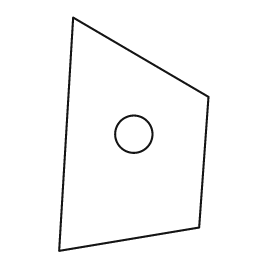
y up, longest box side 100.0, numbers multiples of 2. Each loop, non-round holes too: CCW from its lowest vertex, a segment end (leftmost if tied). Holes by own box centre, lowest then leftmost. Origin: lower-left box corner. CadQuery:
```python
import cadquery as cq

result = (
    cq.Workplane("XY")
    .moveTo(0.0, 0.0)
    .lineTo(60.0, 10.0)
    .lineTo(64.0, 66.0)
    .lineTo(6.0, 100.0)
    .close()
    .moveTo(32.0, 50.0)
    .circle(8.0)
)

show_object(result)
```